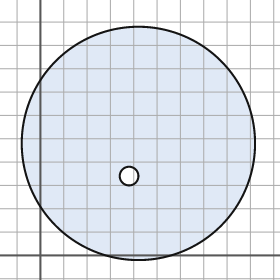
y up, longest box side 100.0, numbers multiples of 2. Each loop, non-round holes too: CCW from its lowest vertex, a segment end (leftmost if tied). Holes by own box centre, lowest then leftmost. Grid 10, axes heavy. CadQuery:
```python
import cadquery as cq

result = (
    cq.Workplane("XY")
    .moveTo(42.0, 48.0)
    .circle(50.0)
    .moveTo(38.0, 34.0)
    .circle(4.0)
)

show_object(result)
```